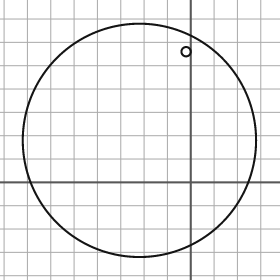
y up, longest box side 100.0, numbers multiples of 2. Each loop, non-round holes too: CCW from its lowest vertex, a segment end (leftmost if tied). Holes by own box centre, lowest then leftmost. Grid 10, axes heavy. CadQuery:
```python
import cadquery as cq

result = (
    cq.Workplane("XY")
    .moveTo(-22.0, 18.0)
    .circle(50.0)
    .moveTo(-2.0, 56.0)
    .circle(2.0)
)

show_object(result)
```